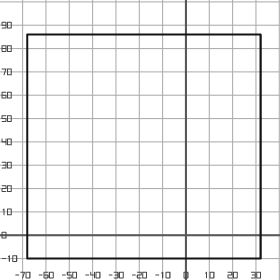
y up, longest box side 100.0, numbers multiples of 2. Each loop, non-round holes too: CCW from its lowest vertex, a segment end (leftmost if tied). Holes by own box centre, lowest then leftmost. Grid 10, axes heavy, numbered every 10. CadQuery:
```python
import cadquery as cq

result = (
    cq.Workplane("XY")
    .moveTo(-68.0, -10.0)
    .lineTo(32.0, -10.0)
    .lineTo(32.0, 86.0)
    .lineTo(-68.0, 86.0)
    .close()
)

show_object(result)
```